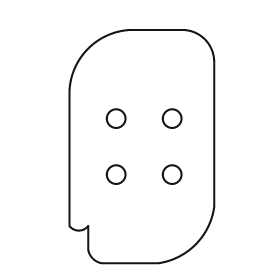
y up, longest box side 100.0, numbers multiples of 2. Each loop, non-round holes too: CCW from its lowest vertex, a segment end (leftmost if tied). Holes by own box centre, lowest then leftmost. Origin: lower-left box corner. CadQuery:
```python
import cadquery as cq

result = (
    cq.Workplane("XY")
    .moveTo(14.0, 0.0)
    .lineTo(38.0, 0.0)
    .threePointArc((54.0, 8.0), (62.0, 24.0))
    .lineTo(62.0, 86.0)
    .threePointArc((58.0, 96.0), (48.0, 100.0))
    .lineTo(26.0, 100.0)
    .threePointArc((8.0, 92.0), (0.0, 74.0))
    .lineTo(0.0, 16.0)
    .threePointArc((4.0, 14.0), (8.0, 16.0))
    .lineTo(8.0, 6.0)
    .threePointArc((10.0, 2.0), (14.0, 0.0))
    .close()
    .moveTo(20.0, 38.0)
    .circle(4.0)
    .moveTo(44.0, 38.0)
    .circle(4.0)
    .moveTo(20.0, 62.0)
    .circle(4.0)
    .moveTo(44.0, 62.0)
    .circle(4.0)
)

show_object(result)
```